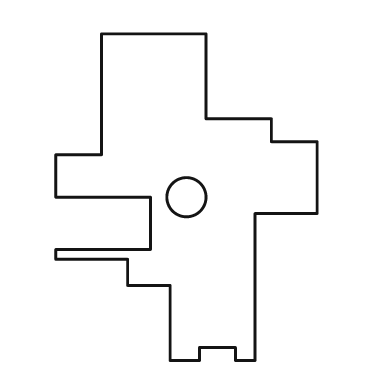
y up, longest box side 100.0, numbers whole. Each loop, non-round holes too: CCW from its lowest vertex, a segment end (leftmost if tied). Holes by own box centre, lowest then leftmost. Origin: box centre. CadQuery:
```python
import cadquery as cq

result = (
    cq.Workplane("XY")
    .moveTo(-5.0, -50.0)
    .lineTo(4.0, -50.0)
    .lineTo(4.0, -46.0)
    .lineTo(15.0, -46.0)
    .lineTo(15.0, -50.0)
    .lineTo(21.0, -50.0)
    .lineTo(21.0, -5.0)
    .lineTo(40.0, -5.0)
    .lineTo(40.0, 17.0)
    .lineTo(26.0, 17.0)
    .lineTo(26.0, 24.0)
    .lineTo(6.0, 24.0)
    .lineTo(6.0, 50.0)
    .lineTo(-26.0, 50.0)
    .lineTo(-26.0, 13.0)
    .lineTo(-40.0, 13.0)
    .lineTo(-40.0, 0.0)
    .lineTo(-11.0, 0.0)
    .lineTo(-11.0, -16.0)
    .lineTo(-40.0, -16.0)
    .lineTo(-40.0, -19.0)
    .lineTo(-18.0, -19.0)
    .lineTo(-18.0, -27.0)
    .lineTo(-5.0, -27.0)
    .close()
    .moveTo(0.0, 0.0)
    .circle(6.0)
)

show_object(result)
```